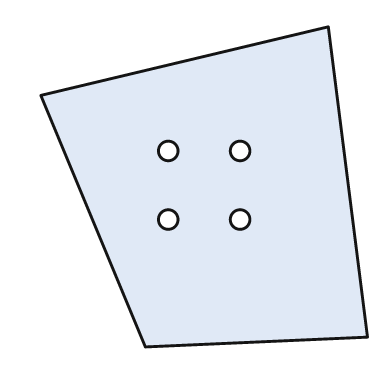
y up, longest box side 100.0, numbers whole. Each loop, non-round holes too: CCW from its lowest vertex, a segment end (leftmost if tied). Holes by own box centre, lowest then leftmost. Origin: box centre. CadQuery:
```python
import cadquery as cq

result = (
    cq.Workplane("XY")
    .moveTo(-18.0, -49.0)
    .lineTo(50.0, -46.0)
    .lineTo(38.0, 49.0)
    .lineTo(-50.0, 28.0)
    .close()
    .moveTo(-11.0, -10.0)
    .circle(3.0)
    .moveTo(11.0, -10.0)
    .circle(3.0)
    .moveTo(-11.0, 11.0)
    .circle(3.0)
    .moveTo(11.0, 11.0)
    .circle(3.0)
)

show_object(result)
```